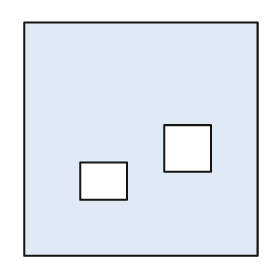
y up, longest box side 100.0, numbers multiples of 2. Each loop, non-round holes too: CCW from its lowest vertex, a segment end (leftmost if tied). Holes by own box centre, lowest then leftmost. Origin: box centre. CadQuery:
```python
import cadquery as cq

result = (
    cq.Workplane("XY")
    .moveTo(-50.0, -50.0)
    .lineTo(50.0, -50.0)
    .lineTo(50.0, 50.0)
    .lineTo(-50.0, 50.0)
    .close()
    .moveTo(-26.0, -26.0)
    .lineTo(-6.0, -26.0)
    .lineTo(-6.0, -10.0)
    .lineTo(-26.0, -10.0)
    .close()
    .moveTo(10.0, -14.0)
    .lineTo(30.0, -14.0)
    .lineTo(30.0, 6.0)
    .lineTo(10.0, 6.0)
    .close()
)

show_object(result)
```